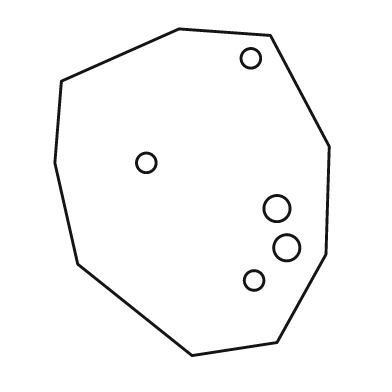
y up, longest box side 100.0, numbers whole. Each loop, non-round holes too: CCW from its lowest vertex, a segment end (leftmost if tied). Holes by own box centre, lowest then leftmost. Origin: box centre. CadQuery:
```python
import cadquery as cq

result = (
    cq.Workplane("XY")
    .moveTo(0.0, -50.0)
    .lineTo(26.0, -46.0)
    .lineTo(41.0, -19.0)
    .lineTo(42.0, 14.0)
    .lineTo(24.0, 48.0)
    .lineTo(-4.0, 50.0)
    .lineTo(-40.0, 34.0)
    .lineTo(-42.0, 9.0)
    .lineTo(-35.0, -22.0)
    .close()
    .moveTo(19.0, -27.0)
    .circle(3.0)
    .moveTo(29.0, -17.0)
    .circle(4.0)
    .moveTo(26.0, -5.0)
    .circle(4.0)
    .moveTo(-14.0, 9.0)
    .circle(3.0)
    .moveTo(18.0, 41.0)
    .circle(3.0)
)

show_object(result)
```